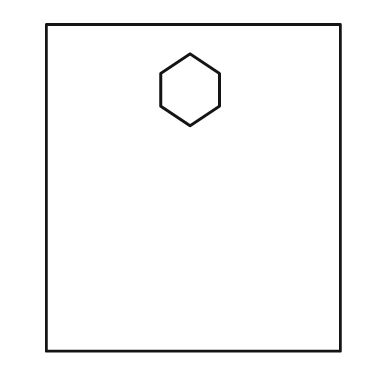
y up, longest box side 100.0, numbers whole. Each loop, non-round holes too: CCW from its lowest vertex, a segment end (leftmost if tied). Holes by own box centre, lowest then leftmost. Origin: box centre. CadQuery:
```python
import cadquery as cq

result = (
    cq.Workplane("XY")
    .moveTo(-45.0, -50.0)
    .lineTo(45.0, -50.0)
    .lineTo(45.0, 50.0)
    .lineTo(-45.0, 50.0)
    .close()
    .moveTo(-1.0, 19.0)
    .lineTo(8.0, 25.0)
    .lineTo(8.0, 35.0)
    .lineTo(-1.0, 41.0)
    .lineTo(-10.0, 35.0)
    .lineTo(-10.0, 25.0)
    .close()
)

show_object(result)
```